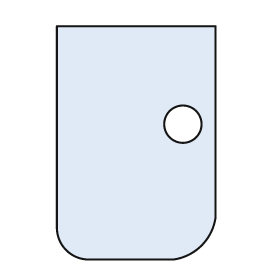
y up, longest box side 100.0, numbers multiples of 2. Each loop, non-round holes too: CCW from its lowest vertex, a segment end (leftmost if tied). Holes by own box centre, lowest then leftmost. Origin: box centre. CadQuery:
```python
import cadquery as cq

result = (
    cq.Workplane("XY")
    .moveTo(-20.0, -50.0)
    .lineTo(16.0, -50.0)
    .threePointArc((28.0, -44.0), (34.0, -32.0))
    .lineTo(34.0, 50.0)
    .lineTo(-34.0, 50.0)
    .lineTo(-34.0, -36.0)
    .threePointArc((-30.0, -46.0), (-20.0, -50.0))
    .close()
    .moveTo(20.0, 8.0)
    .circle(8.0)
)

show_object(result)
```